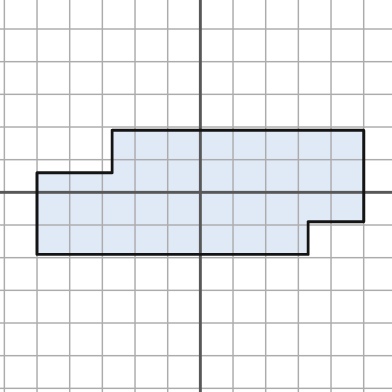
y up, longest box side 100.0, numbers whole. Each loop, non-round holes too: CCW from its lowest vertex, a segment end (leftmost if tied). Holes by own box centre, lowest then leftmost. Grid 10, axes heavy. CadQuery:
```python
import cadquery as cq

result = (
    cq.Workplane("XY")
    .moveTo(-50.0, -19.0)
    .lineTo(33.0, -19.0)
    .lineTo(33.0, -9.0)
    .lineTo(50.0, -9.0)
    .lineTo(50.0, 19.0)
    .lineTo(-27.0, 19.0)
    .lineTo(-27.0, 6.0)
    .lineTo(-50.0, 6.0)
    .close()
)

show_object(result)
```